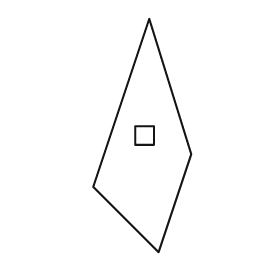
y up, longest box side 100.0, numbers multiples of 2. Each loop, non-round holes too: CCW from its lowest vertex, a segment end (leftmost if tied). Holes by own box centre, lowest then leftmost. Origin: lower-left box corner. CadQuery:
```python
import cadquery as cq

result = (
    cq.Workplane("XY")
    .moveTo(28.0, 0.0)
    .lineTo(42.0, 42.0)
    .lineTo(24.0, 100.0)
    .lineTo(0.0, 28.0)
    .close()
    .moveTo(18.0, 46.0)
    .lineTo(26.0, 46.0)
    .lineTo(26.0, 54.0)
    .lineTo(18.0, 54.0)
    .close()
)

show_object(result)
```